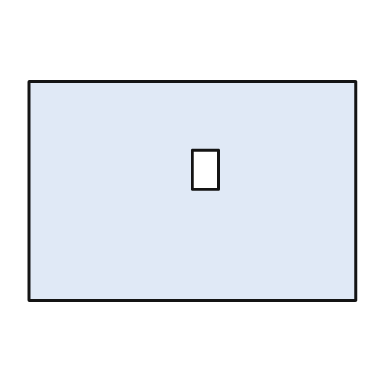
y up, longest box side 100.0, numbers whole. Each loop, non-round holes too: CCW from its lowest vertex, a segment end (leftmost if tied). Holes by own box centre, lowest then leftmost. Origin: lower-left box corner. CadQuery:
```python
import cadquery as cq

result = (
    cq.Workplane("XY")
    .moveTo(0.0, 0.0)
    .lineTo(100.0, 0.0)
    .lineTo(100.0, 67.0)
    .lineTo(0.0, 67.0)
    .close()
    .moveTo(50.0, 34.0)
    .lineTo(58.0, 34.0)
    .lineTo(58.0, 46.0)
    .lineTo(50.0, 46.0)
    .close()
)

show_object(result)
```